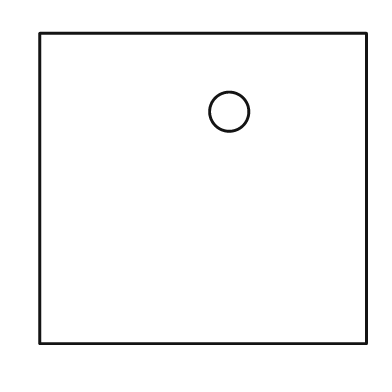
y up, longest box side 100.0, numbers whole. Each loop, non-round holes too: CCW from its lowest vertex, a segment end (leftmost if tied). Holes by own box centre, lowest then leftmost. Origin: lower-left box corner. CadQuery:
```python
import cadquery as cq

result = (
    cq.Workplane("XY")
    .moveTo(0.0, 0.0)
    .lineTo(100.0, 0.0)
    .lineTo(100.0, 95.0)
    .lineTo(0.0, 95.0)
    .close()
    .moveTo(58.0, 71.0)
    .circle(6.0)
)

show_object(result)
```